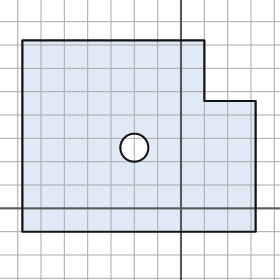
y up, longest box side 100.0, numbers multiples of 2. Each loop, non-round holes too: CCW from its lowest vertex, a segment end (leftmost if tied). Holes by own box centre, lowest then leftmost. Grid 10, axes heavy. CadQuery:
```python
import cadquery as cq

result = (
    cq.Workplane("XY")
    .moveTo(-68.0, -10.0)
    .lineTo(32.0, -10.0)
    .lineTo(32.0, 46.0)
    .lineTo(10.0, 46.0)
    .lineTo(10.0, 72.0)
    .lineTo(-68.0, 72.0)
    .close()
    .moveTo(-20.0, 26.0)
    .circle(6.0)
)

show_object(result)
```